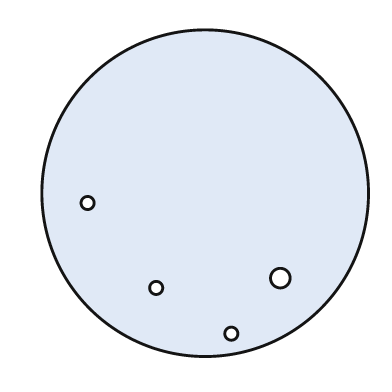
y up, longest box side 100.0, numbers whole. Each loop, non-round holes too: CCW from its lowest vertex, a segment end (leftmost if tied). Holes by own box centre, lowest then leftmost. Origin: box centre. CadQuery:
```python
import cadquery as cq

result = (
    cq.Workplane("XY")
    .moveTo(0.0, 0.0)
    .circle(50.0)
    .moveTo(8.0, -43.0)
    .circle(2.0)
    .moveTo(-15.0, -29.0)
    .circle(2.0)
    .moveTo(23.0, -26.0)
    .circle(3.0)
    .moveTo(-36.0, -3.0)
    .circle(2.0)
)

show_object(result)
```